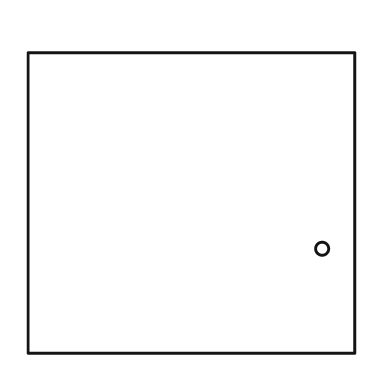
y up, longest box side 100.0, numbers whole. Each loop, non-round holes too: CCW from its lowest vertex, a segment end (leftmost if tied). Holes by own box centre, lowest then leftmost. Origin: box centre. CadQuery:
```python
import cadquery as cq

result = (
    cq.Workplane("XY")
    .moveTo(-50.0, -46.0)
    .lineTo(50.0, -46.0)
    .lineTo(50.0, 46.0)
    .lineTo(-50.0, 46.0)
    .close()
    .moveTo(40.0, -14.0)
    .circle(2.0)
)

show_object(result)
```